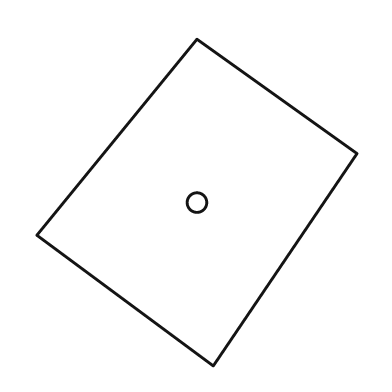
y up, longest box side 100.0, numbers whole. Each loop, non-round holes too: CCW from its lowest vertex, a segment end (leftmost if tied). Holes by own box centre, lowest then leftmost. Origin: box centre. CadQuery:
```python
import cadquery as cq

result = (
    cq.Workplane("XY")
    .moveTo(5.0, -50.0)
    .lineTo(49.0, 15.0)
    .lineTo(0.0, 50.0)
    .lineTo(-49.0, -10.0)
    .close()
    .moveTo(0.0, 0.0)
    .circle(3.0)
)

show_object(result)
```